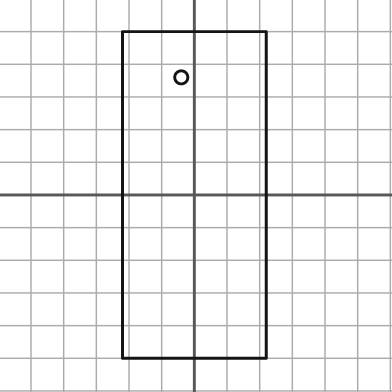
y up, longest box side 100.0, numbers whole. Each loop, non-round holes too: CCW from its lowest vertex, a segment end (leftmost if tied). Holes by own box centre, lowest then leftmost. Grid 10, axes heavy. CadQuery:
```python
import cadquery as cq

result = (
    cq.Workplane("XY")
    .moveTo(-22.0, -50.0)
    .lineTo(22.0, -50.0)
    .lineTo(22.0, 50.0)
    .lineTo(-22.0, 50.0)
    .close()
    .moveTo(-4.0, 36.0)
    .circle(2.0)
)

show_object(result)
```